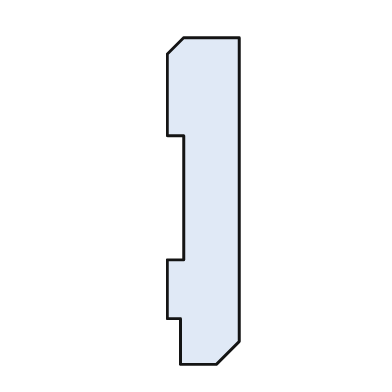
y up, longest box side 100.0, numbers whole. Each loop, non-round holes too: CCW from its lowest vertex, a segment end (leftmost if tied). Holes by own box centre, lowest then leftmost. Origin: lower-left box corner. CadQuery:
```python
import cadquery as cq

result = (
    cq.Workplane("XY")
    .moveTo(4.0, 0.0)
    .lineTo(15.0, 0.0)
    .lineTo(22.0, 7.0)
    .lineTo(22.0, 100.0)
    .lineTo(5.0, 100.0)
    .lineTo(0.0, 95.0)
    .lineTo(0.0, 70.0)
    .lineTo(5.0, 70.0)
    .lineTo(5.0, 32.0)
    .lineTo(0.0, 32.0)
    .lineTo(0.0, 14.0)
    .lineTo(4.0, 14.0)
    .close()
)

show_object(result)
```